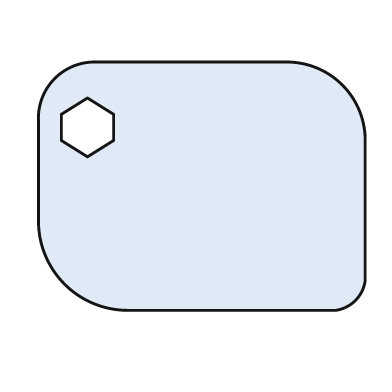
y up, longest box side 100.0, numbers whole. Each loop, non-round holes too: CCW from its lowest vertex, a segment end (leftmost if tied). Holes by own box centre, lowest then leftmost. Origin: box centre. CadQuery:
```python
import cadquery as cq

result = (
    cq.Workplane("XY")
    .moveTo(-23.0, -38.0)
    .lineTo(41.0, -38.0)
    .threePointArc((47.0, -35.0), (50.0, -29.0))
    .lineTo(50.0, 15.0)
    .threePointArc((43.0, 31.0), (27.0, 38.0))
    .lineTo(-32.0, 38.0)
    .threePointArc((-45.0, 33.0), (-50.0, 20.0))
    .lineTo(-50.0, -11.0)
    .threePointArc((-42.0, -30.0), (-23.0, -38.0))
    .close()
    .moveTo(-35.0, 9.0)
    .lineTo(-27.0, 14.0)
    .lineTo(-27.0, 22.0)
    .lineTo(-35.0, 27.0)
    .lineTo(-43.0, 22.0)
    .lineTo(-43.0, 14.0)
    .close()
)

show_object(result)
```